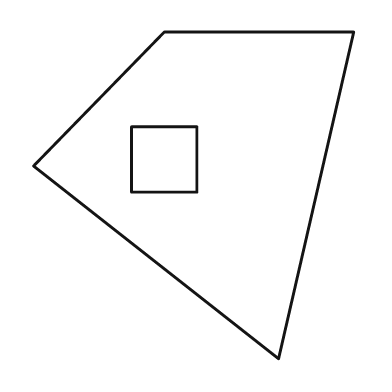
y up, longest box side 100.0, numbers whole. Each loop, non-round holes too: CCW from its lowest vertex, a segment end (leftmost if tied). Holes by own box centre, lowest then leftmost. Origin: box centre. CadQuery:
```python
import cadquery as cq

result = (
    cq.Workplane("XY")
    .moveTo(26.0, -50.0)
    .lineTo(49.0, 50.0)
    .lineTo(-9.0, 50.0)
    .lineTo(-49.0, 9.0)
    .close()
    .moveTo(-19.0, 1.0)
    .lineTo(1.0, 1.0)
    .lineTo(1.0, 21.0)
    .lineTo(-19.0, 21.0)
    .close()
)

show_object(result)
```